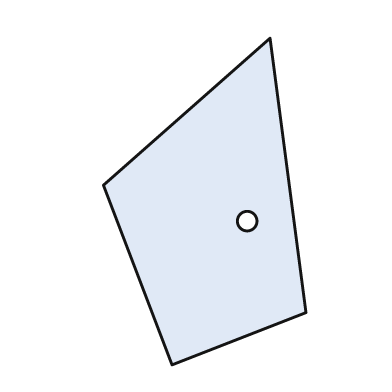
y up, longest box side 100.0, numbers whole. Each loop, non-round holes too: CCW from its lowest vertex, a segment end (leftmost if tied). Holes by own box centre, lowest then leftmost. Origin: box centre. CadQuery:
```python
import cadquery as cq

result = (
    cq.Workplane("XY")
    .moveTo(-10.0, -50.0)
    .lineTo(31.0, -34.0)
    .lineTo(20.0, 50.0)
    .lineTo(-31.0, 5.0)
    .close()
    .moveTo(13.0, -6.0)
    .circle(3.0)
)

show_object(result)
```